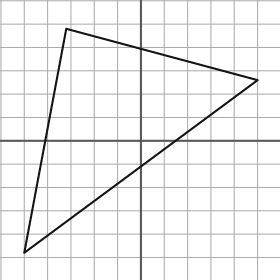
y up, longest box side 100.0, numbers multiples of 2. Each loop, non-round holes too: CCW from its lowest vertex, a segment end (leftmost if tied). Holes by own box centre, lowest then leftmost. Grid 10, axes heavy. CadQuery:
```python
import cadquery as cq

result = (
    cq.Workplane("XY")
    .moveTo(-50.0, -48.0)
    .lineTo(50.0, 26.0)
    .lineTo(-32.0, 48.0)
    .close()
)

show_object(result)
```